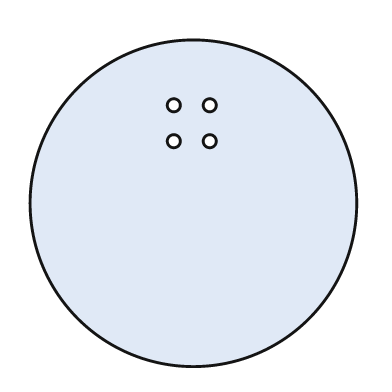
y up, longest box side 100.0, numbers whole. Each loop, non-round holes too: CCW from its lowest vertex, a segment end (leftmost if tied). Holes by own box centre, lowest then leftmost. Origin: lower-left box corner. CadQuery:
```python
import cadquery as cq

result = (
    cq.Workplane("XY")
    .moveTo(50.0, 50.0)
    .circle(50.0)
    .moveTo(44.0, 69.0)
    .circle(2.0)
    .moveTo(55.0, 69.0)
    .circle(2.0)
    .moveTo(44.0, 80.0)
    .circle(2.0)
    .moveTo(55.0, 80.0)
    .circle(2.0)
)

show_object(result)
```